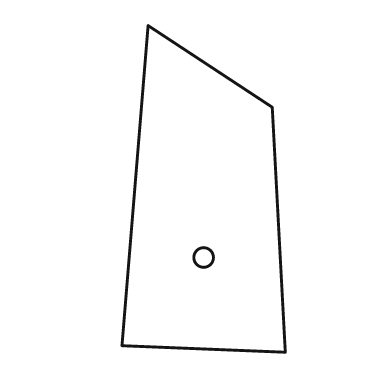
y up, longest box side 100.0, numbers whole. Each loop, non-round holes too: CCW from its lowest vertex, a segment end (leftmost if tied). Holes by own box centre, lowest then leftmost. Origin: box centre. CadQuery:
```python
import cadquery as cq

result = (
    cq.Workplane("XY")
    .moveTo(25.0, -50.0)
    .lineTo(21.0, 25.0)
    .lineTo(-17.0, 50.0)
    .lineTo(-25.0, -48.0)
    .close()
    .moveTo(0.0, -21.0)
    .circle(3.0)
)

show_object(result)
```